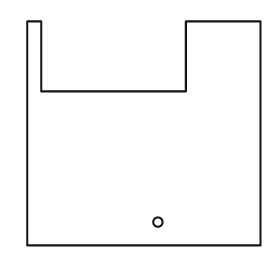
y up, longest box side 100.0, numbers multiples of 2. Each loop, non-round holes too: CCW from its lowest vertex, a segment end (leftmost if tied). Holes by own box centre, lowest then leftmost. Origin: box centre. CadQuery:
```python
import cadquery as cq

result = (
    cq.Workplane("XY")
    .moveTo(-50.0, -48.0)
    .lineTo(50.0, -48.0)
    .lineTo(50.0, 48.0)
    .lineTo(18.0, 48.0)
    .lineTo(18.0, 18.0)
    .lineTo(-44.0, 18.0)
    .lineTo(-44.0, 48.0)
    .lineTo(-50.0, 48.0)
    .close()
    .moveTo(6.0, -38.0)
    .circle(2.0)
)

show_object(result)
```